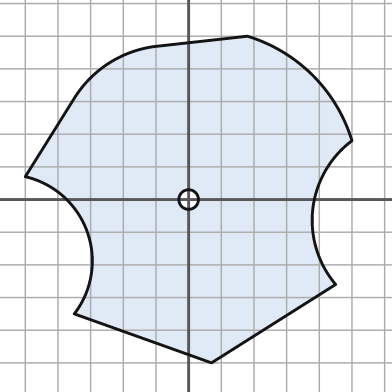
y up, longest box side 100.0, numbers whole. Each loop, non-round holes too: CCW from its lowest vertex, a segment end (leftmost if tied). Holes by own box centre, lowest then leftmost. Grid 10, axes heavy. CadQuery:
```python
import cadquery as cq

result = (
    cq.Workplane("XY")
    .moveTo(7.0, -50.0)
    .lineTo(45.0, -26.0)
    .threePointArc((38.0, -3.0), (50.0, 18.0))
    .threePointArc((38.0, 38.0), (18.0, 50.0))
    .lineTo(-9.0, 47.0)
    .threePointArc((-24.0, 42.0), (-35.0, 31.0))
    .lineTo(-50.0, 7.0)
    .threePointArc((-31.0, -10.0), (-35.0, -35.0))
    .close()
    .moveTo(0.0, 0.0)
    .circle(3.0)
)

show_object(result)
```